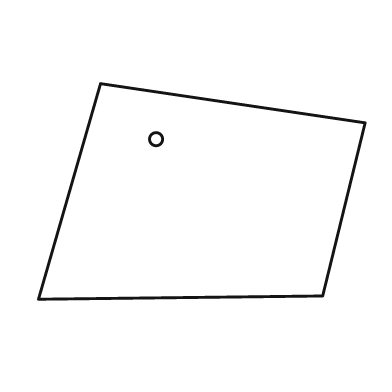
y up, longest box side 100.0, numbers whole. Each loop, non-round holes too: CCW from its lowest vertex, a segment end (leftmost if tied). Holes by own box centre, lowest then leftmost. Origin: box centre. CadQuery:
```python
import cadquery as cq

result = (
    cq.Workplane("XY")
    .moveTo(-50.0, -33.0)
    .lineTo(37.0, -32.0)
    .lineTo(50.0, 21.0)
    .lineTo(-31.0, 33.0)
    .close()
    .moveTo(-14.0, 16.0)
    .circle(2.0)
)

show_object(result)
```